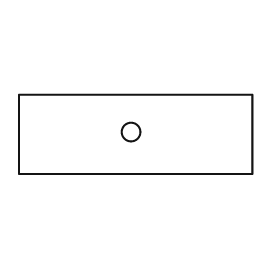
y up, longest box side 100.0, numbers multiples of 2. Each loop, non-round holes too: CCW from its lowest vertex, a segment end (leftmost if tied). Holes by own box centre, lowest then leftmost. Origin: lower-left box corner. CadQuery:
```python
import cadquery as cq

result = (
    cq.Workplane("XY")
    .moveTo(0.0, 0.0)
    .lineTo(100.0, 0.0)
    .lineTo(100.0, 34.0)
    .lineTo(0.0, 34.0)
    .close()
    .moveTo(48.0, 18.0)
    .circle(4.0)
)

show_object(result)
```